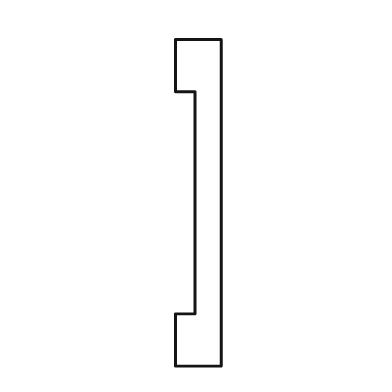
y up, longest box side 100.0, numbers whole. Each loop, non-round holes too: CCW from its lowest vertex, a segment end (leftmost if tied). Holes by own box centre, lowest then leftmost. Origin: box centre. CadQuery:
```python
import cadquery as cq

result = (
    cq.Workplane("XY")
    .moveTo(-7.0, -50.0)
    .lineTo(7.0, -50.0)
    .lineTo(7.0, 50.0)
    .lineTo(-7.0, 50.0)
    .lineTo(-7.0, 34.0)
    .lineTo(-1.0, 34.0)
    .lineTo(-1.0, -34.0)
    .lineTo(-7.0, -34.0)
    .close()
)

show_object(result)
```